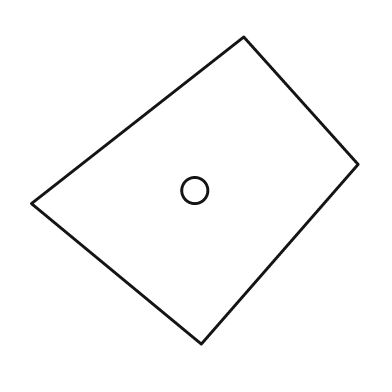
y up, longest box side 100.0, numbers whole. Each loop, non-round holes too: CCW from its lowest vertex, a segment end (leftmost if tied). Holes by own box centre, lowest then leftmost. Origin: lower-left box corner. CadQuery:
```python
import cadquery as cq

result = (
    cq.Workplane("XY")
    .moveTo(52.0, 0.0)
    .lineTo(100.0, 55.0)
    .lineTo(65.0, 94.0)
    .lineTo(0.0, 43.0)
    .close()
    .moveTo(50.0, 47.0)
    .circle(4.0)
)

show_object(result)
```